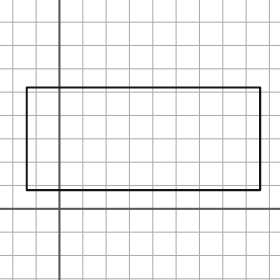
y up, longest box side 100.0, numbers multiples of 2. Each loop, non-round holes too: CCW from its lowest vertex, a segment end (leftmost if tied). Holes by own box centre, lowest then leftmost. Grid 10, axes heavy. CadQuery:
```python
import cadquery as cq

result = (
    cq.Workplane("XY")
    .moveTo(-14.0, 8.0)
    .lineTo(86.0, 8.0)
    .lineTo(86.0, 52.0)
    .lineTo(-14.0, 52.0)
    .close()
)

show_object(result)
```